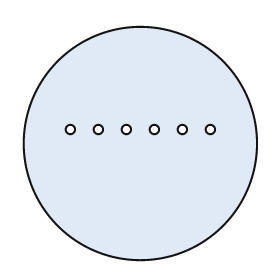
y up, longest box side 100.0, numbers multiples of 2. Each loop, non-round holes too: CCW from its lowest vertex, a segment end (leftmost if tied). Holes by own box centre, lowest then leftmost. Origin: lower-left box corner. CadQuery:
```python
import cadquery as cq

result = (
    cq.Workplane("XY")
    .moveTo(50.0, 50.0)
    .circle(50.0)
    .moveTo(20.0, 56.0)
    .circle(2.0)
    .moveTo(32.0, 56.0)
    .circle(2.0)
    .moveTo(44.0, 56.0)
    .circle(2.0)
    .moveTo(56.0, 56.0)
    .circle(2.0)
    .moveTo(68.0, 56.0)
    .circle(2.0)
    .moveTo(80.0, 56.0)
    .circle(2.0)
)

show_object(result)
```